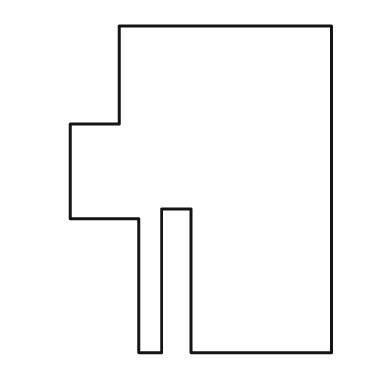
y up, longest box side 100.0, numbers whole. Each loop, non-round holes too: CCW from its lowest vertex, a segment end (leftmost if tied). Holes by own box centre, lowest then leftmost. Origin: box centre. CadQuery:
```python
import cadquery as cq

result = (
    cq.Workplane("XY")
    .moveTo(-19.0, -50.0)
    .lineTo(-12.0, -50.0)
    .lineTo(-12.0, -6.0)
    .lineTo(-3.0, -6.0)
    .lineTo(-3.0, -50.0)
    .lineTo(40.0, -50.0)
    .lineTo(40.0, 50.0)
    .lineTo(-25.0, 50.0)
    .lineTo(-25.0, 20.0)
    .lineTo(-40.0, 20.0)
    .lineTo(-40.0, -9.0)
    .lineTo(-19.0, -9.0)
    .close()
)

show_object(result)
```